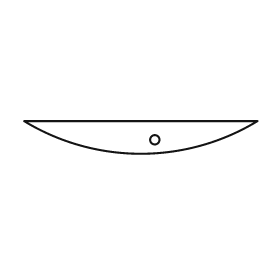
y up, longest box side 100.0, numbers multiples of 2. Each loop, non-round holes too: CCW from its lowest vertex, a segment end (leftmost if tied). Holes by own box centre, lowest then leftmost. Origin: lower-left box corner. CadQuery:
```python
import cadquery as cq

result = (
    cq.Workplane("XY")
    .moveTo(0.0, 14.0)
    .threePointArc((50.0, 0.0), (100.0, 14.0))
    .close()
    .moveTo(56.0, 6.0)
    .circle(2.0)
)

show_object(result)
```